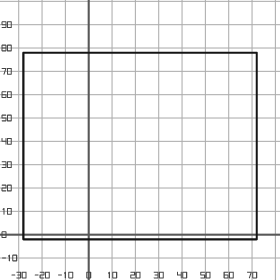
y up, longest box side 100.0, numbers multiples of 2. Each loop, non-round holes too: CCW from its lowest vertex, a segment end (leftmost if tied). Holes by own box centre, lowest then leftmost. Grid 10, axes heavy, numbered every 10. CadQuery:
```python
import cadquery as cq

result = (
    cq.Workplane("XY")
    .moveTo(-28.0, -2.0)
    .lineTo(72.0, -2.0)
    .lineTo(72.0, 78.0)
    .lineTo(-28.0, 78.0)
    .close()
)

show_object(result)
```